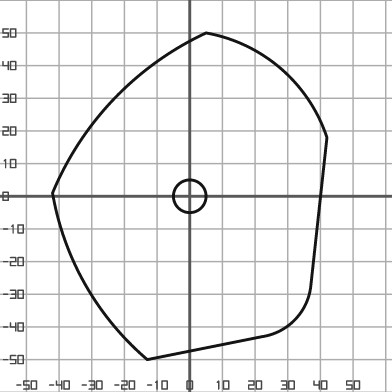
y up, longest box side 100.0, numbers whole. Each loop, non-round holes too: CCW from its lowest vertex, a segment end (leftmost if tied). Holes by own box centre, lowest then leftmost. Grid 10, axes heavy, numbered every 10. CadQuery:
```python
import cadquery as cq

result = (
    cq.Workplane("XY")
    .moveTo(-13.0, -50.0)
    .lineTo(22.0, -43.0)
    .threePointArc((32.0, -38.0), (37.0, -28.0))
    .lineTo(42.0, 18.0)
    .threePointArc((28.0, 39.0), (5.0, 50.0))
    .threePointArc((-23.0, 30.0), (-42.0, 1.0))
    .threePointArc((-32.0, -27.0), (-13.0, -50.0))
    .close()
    .moveTo(0.0, 0.0)
    .circle(5.0)
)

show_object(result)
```